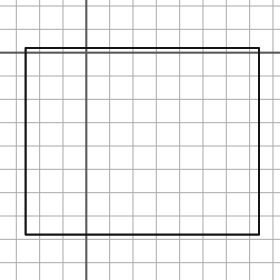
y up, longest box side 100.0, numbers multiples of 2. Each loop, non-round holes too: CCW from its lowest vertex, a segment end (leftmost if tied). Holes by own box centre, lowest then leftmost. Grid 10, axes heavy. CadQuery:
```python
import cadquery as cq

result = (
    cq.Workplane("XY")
    .moveTo(-26.0, -78.0)
    .lineTo(74.0, -78.0)
    .lineTo(74.0, 2.0)
    .lineTo(-26.0, 2.0)
    .close()
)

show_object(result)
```